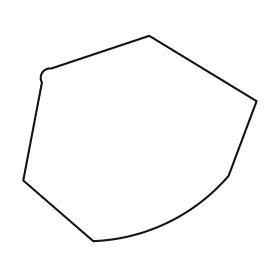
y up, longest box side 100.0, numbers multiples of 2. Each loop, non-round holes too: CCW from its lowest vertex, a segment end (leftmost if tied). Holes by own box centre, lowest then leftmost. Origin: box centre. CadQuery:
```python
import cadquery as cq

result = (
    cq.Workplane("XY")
    .moveTo(-20.0, -44.0)
    .threePointArc((12.0, -36.0), (38.0, -16.0))
    .lineTo(50.0, 16.0)
    .lineTo(4.0, 44.0)
    .lineTo(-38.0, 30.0)
    .threePointArc((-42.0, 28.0), (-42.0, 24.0))
    .lineTo(-50.0, -18.0)
    .close()
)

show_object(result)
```